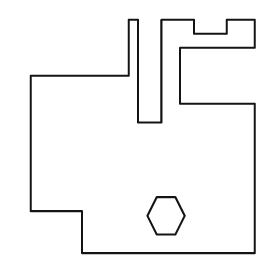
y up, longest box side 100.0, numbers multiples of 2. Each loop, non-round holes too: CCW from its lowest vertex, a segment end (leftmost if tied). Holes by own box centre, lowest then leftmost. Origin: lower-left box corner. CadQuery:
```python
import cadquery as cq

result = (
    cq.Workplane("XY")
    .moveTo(22.0, 0.0)
    .lineTo(96.0, 0.0)
    .lineTo(96.0, 64.0)
    .lineTo(64.0, 64.0)
    .lineTo(64.0, 88.0)
    .lineTo(96.0, 88.0)
    .lineTo(96.0, 100.0)
    .lineTo(84.0, 100.0)
    .lineTo(84.0, 94.0)
    .lineTo(70.0, 94.0)
    .lineTo(70.0, 100.0)
    .lineTo(56.0, 100.0)
    .lineTo(56.0, 56.0)
    .lineTo(46.0, 56.0)
    .lineTo(46.0, 100.0)
    .lineTo(42.0, 100.0)
    .lineTo(42.0, 76.0)
    .lineTo(0.0, 76.0)
    .lineTo(0.0, 18.0)
    .lineTo(22.0, 18.0)
    .close()
    .moveTo(54.0, 8.0)
    .lineTo(62.0, 8.0)
    .lineTo(66.0, 16.0)
    .lineTo(62.0, 24.0)
    .lineTo(54.0, 24.0)
    .lineTo(50.0, 16.0)
    .close()
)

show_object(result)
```